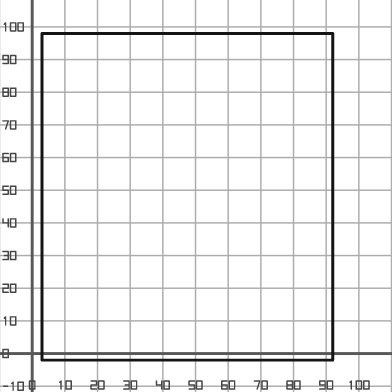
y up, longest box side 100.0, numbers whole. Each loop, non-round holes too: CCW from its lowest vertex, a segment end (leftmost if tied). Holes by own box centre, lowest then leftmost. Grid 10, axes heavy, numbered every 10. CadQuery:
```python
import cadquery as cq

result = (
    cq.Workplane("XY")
    .moveTo(3.0, -2.0)
    .lineTo(92.0, -2.0)
    .lineTo(92.0, 98.0)
    .lineTo(3.0, 98.0)
    .close()
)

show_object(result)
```